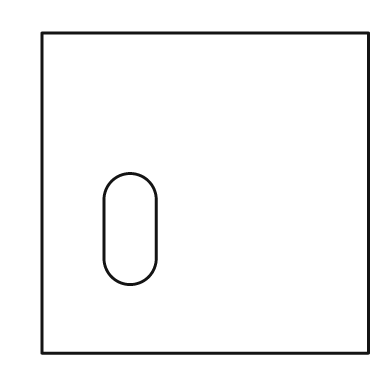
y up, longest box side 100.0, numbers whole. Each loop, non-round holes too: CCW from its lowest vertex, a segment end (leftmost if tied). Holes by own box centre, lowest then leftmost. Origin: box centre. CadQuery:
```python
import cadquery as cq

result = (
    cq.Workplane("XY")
    .moveTo(-50.0, -49.0)
    .lineTo(50.0, -49.0)
    .lineTo(50.0, 49.0)
    .lineTo(-50.0, 49.0)
    .close()
    .moveTo(-31.0, -20.0)
    .threePointArc((-23.0, -28.0), (-15.0, -20.0))
    .lineTo(-15.0, -2.0)
    .threePointArc((-23.0, 6.0), (-31.0, -2.0))
    .close()
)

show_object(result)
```